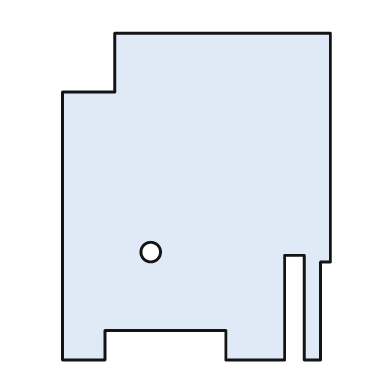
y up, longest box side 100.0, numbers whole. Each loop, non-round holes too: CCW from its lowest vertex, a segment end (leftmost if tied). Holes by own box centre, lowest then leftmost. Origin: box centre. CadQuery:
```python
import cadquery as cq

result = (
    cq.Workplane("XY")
    .moveTo(-41.0, -50.0)
    .lineTo(-28.0, -50.0)
    .lineTo(-28.0, -41.0)
    .lineTo(9.0, -41.0)
    .lineTo(9.0, -50.0)
    .lineTo(27.0, -50.0)
    .lineTo(27.0, -18.0)
    .lineTo(33.0, -18.0)
    .lineTo(33.0, -50.0)
    .lineTo(38.0, -50.0)
    .lineTo(38.0, -20.0)
    .lineTo(41.0, -20.0)
    .lineTo(41.0, 50.0)
    .lineTo(-25.0, 50.0)
    .lineTo(-25.0, 32.0)
    .lineTo(-41.0, 32.0)
    .close()
    .moveTo(-14.0, -17.0)
    .circle(3.0)
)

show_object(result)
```